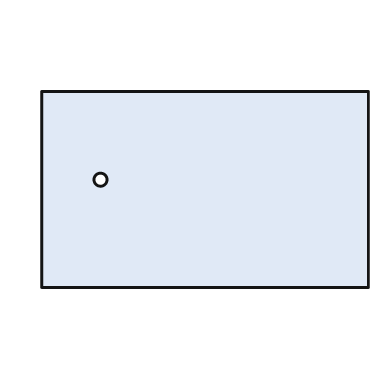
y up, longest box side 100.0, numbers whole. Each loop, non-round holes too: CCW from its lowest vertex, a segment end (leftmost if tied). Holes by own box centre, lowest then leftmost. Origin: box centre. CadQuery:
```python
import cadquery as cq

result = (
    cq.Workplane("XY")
    .moveTo(-50.0, -30.0)
    .lineTo(50.0, -30.0)
    .lineTo(50.0, 30.0)
    .lineTo(-50.0, 30.0)
    .close()
    .moveTo(-32.0, 3.0)
    .circle(2.0)
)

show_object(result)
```